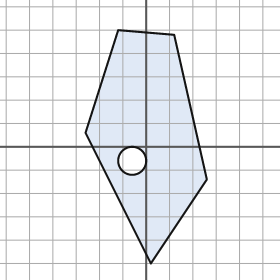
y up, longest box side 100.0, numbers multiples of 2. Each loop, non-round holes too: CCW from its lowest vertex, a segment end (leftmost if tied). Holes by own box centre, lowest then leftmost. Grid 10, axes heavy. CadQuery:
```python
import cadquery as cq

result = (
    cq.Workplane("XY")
    .moveTo(2.0, -50.0)
    .lineTo(26.0, -14.0)
    .lineTo(12.0, 48.0)
    .lineTo(-12.0, 50.0)
    .lineTo(-26.0, 6.0)
    .close()
    .moveTo(-6.0, -6.0)
    .circle(6.0)
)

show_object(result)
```